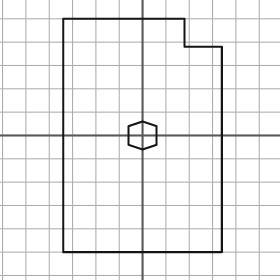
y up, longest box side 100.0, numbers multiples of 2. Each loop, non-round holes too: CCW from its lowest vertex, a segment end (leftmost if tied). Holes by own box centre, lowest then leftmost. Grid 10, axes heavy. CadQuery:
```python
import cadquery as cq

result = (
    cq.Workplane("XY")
    .moveTo(-34.0, -50.0)
    .lineTo(34.0, -50.0)
    .lineTo(34.0, 38.0)
    .lineTo(18.0, 38.0)
    .lineTo(18.0, 50.0)
    .lineTo(-34.0, 50.0)
    .close()
    .moveTo(0.0, -6.0)
    .lineTo(6.0, -4.0)
    .lineTo(6.0, 4.0)
    .lineTo(0.0, 6.0)
    .lineTo(-6.0, 4.0)
    .lineTo(-6.0, -4.0)
    .close()
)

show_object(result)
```